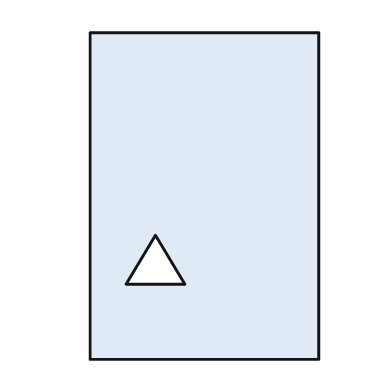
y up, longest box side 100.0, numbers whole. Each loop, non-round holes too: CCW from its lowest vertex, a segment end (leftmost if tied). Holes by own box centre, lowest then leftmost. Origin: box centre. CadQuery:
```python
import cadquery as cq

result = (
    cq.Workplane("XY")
    .moveTo(-35.0, -50.0)
    .lineTo(35.0, -50.0)
    .lineTo(35.0, 50.0)
    .lineTo(-35.0, 50.0)
    .close()
    .moveTo(-24.0, -27.0)
    .lineTo(-6.0, -27.0)
    .lineTo(-15.0, -12.0)
    .close()
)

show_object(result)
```